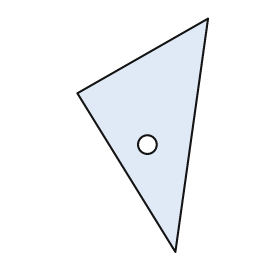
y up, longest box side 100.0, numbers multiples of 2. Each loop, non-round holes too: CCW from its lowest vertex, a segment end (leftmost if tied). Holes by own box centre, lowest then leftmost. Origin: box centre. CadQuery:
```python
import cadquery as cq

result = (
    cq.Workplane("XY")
    .moveTo(14.0, -50.0)
    .lineTo(28.0, 50.0)
    .lineTo(-28.0, 18.0)
    .close()
    .moveTo(2.0, -4.0)
    .circle(4.0)
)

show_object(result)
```